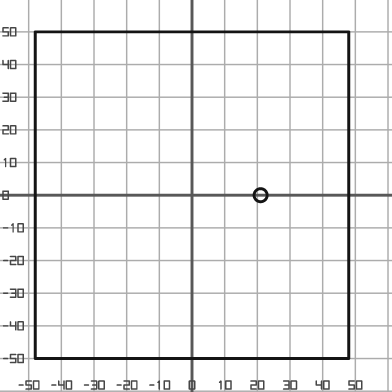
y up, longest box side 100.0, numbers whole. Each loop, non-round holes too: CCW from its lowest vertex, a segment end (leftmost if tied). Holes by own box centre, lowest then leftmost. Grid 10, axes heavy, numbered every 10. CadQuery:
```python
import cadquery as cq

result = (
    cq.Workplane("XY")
    .moveTo(-48.0, -50.0)
    .lineTo(48.0, -50.0)
    .lineTo(48.0, 50.0)
    .lineTo(-48.0, 50.0)
    .close()
    .moveTo(21.0, 0.0)
    .circle(2.0)
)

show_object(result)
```